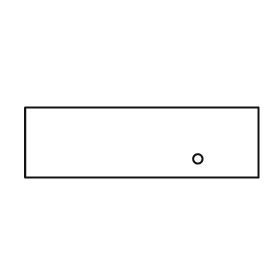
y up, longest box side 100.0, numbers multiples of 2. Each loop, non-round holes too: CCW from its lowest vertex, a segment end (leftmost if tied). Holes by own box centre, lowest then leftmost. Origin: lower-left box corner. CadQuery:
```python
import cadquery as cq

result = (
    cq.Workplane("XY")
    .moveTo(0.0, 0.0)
    .lineTo(100.0, 0.0)
    .lineTo(100.0, 30.0)
    .lineTo(0.0, 30.0)
    .close()
    .moveTo(74.0, 8.0)
    .circle(2.0)
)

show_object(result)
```